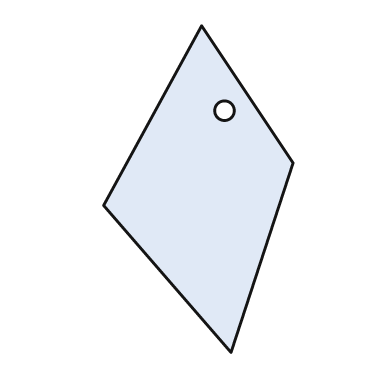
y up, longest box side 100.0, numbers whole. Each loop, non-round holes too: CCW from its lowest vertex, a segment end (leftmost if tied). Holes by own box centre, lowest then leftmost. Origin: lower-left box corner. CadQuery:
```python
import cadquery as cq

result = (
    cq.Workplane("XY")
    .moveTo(39.0, 0.0)
    .lineTo(58.0, 58.0)
    .lineTo(30.0, 100.0)
    .lineTo(0.0, 45.0)
    .close()
    .moveTo(37.0, 74.0)
    .circle(3.0)
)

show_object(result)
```